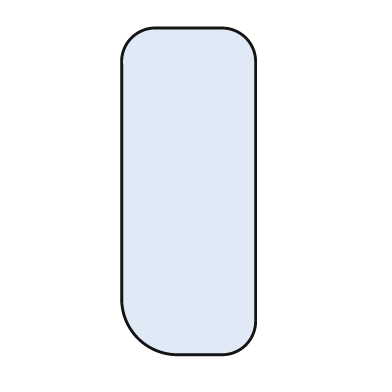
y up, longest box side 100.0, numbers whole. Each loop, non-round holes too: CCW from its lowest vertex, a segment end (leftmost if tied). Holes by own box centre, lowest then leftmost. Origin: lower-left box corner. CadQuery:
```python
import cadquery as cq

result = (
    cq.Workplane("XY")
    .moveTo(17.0, 0.0)
    .lineTo(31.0, 0.0)
    .threePointArc((38.0, 3.0), (41.0, 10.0))
    .lineTo(41.0, 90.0)
    .threePointArc((38.0, 97.0), (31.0, 100.0))
    .lineTo(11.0, 100.0)
    .threePointArc((3.0, 97.0), (0.0, 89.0))
    .lineTo(0.0, 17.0)
    .threePointArc((5.0, 5.0), (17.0, 0.0))
    .close()
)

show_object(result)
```